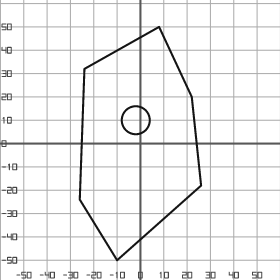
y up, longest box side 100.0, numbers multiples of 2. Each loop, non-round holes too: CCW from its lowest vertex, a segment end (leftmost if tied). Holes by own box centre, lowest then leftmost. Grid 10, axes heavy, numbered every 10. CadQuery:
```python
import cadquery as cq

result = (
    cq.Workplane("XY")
    .moveTo(-10.0, -50.0)
    .lineTo(26.0, -18.0)
    .lineTo(22.0, 20.0)
    .lineTo(8.0, 50.0)
    .lineTo(-24.0, 32.0)
    .lineTo(-26.0, -24.0)
    .close()
    .moveTo(-2.0, 10.0)
    .circle(6.0)
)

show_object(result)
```